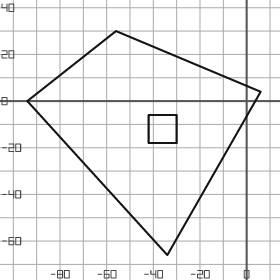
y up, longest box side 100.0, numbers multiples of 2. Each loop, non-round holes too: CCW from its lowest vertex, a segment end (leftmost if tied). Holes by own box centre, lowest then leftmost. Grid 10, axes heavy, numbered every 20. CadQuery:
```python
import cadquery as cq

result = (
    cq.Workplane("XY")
    .moveTo(-34.0, -66.0)
    .lineTo(6.0, 4.0)
    .lineTo(-56.0, 30.0)
    .lineTo(-94.0, 0.0)
    .close()
    .moveTo(-42.0, -18.0)
    .lineTo(-30.0, -18.0)
    .lineTo(-30.0, -6.0)
    .lineTo(-42.0, -6.0)
    .close()
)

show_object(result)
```